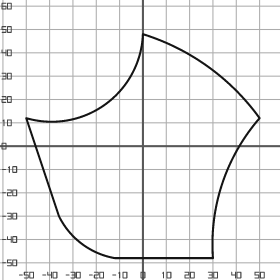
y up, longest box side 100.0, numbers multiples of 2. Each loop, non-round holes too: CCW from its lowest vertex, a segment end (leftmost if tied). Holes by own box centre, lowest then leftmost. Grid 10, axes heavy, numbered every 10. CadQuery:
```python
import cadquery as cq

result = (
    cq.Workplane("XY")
    .moveTo(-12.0, -48.0)
    .lineTo(30.0, -48.0)
    .threePointArc((34.0, -16.0), (50.0, 12.0))
    .threePointArc((28.0, 34.0), (0.0, 48.0))
    .threePointArc((-16.0, 18.0), (-50.0, 12.0))
    .lineTo(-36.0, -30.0)
    .threePointArc((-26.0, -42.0), (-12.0, -48.0))
    .close()
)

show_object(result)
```